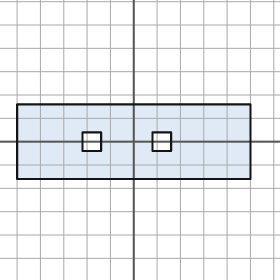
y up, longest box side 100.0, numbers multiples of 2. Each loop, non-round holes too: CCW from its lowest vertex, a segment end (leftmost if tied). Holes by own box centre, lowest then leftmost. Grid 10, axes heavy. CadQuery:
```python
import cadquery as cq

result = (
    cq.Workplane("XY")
    .moveTo(-50.0, -16.0)
    .lineTo(50.0, -16.0)
    .lineTo(50.0, 16.0)
    .lineTo(-50.0, 16.0)
    .close()
    .moveTo(-22.0, -4.0)
    .lineTo(-14.0, -4.0)
    .lineTo(-14.0, 4.0)
    .lineTo(-22.0, 4.0)
    .close()
    .moveTo(8.0, -4.0)
    .lineTo(16.0, -4.0)
    .lineTo(16.0, 4.0)
    .lineTo(8.0, 4.0)
    .close()
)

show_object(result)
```